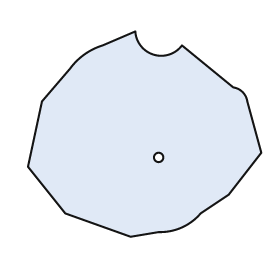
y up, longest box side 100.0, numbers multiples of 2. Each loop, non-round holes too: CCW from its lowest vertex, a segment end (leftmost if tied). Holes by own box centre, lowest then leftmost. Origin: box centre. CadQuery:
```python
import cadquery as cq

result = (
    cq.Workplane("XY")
    .moveTo(-6.0, -44.0)
    .lineTo(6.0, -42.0)
    .threePointArc((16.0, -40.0), (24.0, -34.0))
    .lineTo(36.0, -26.0)
    .lineTo(50.0, -8.0)
    .lineTo(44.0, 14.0)
    .threePointArc((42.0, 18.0), (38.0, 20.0))
    .lineTo(16.0, 38.0)
    .threePointArc((4.0, 34.0), (-4.0, 44.0))
    .lineTo(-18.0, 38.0)
    .threePointArc((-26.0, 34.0), (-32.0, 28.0))
    .lineTo(-44.0, 14.0)
    .lineTo(-50.0, -14.0)
    .lineTo(-34.0, -34.0)
    .close()
    .moveTo(6.0, -10.0)
    .circle(2.0)
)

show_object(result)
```